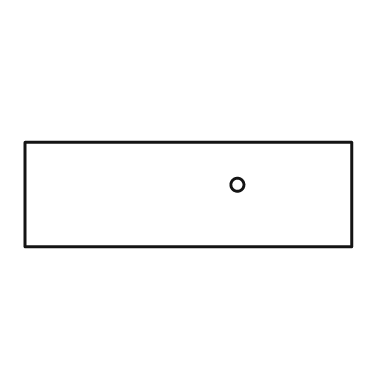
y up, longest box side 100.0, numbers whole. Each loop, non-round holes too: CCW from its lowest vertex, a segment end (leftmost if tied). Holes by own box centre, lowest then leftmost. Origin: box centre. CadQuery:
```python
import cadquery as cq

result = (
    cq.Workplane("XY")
    .moveTo(-50.0, -16.0)
    .lineTo(50.0, -16.0)
    .lineTo(50.0, 16.0)
    .lineTo(-50.0, 16.0)
    .close()
    .moveTo(15.0, 3.0)
    .circle(2.0)
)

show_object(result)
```